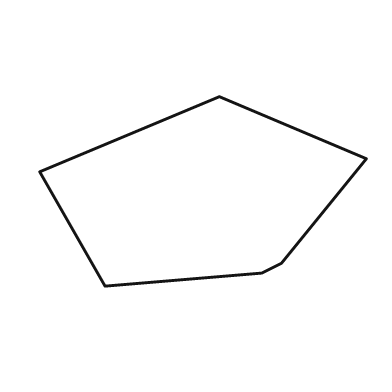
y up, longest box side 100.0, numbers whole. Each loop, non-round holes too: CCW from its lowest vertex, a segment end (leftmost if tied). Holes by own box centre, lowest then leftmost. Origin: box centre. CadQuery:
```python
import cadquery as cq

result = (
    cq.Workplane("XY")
    .moveTo(-30.0, -29.0)
    .lineTo(18.0, -25.0)
    .lineTo(24.0, -22.0)
    .lineTo(50.0, 10.0)
    .lineTo(5.0, 29.0)
    .lineTo(-50.0, 6.0)
    .close()
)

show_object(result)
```